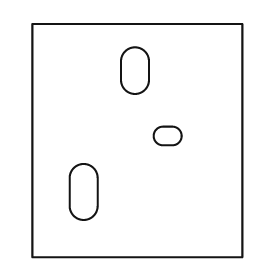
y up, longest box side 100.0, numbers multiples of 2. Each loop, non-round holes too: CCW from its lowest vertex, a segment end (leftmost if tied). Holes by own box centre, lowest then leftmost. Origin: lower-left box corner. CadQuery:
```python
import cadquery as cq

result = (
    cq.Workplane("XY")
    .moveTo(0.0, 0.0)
    .lineTo(90.0, 0.0)
    .lineTo(90.0, 100.0)
    .lineTo(0.0, 100.0)
    .close()
    .moveTo(16.0, 22.0)
    .threePointArc((22.0, 16.0), (28.0, 22.0))
    .lineTo(28.0, 34.0)
    .threePointArc((22.0, 40.0), (16.0, 34.0))
    .close()
    .moveTo(56.0, 48.0)
    .lineTo(60.0, 48.0)
    .threePointArc((64.0, 52.0), (60.0, 56.0))
    .lineTo(56.0, 56.0)
    .threePointArc((52.0, 52.0), (56.0, 48.0))
    .close()
    .moveTo(38.0, 76.0)
    .threePointArc((44.0, 70.0), (50.0, 76.0))
    .lineTo(50.0, 84.0)
    .threePointArc((44.0, 90.0), (38.0, 84.0))
    .close()
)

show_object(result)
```